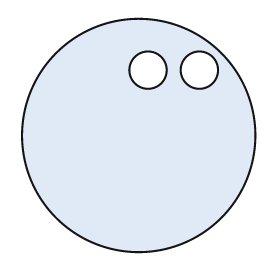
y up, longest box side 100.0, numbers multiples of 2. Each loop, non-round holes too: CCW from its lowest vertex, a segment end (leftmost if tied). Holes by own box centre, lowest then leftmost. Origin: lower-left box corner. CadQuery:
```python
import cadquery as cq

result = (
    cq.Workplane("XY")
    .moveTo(50.0, 50.0)
    .circle(50.0)
    .moveTo(54.0, 78.0)
    .circle(8.0)
    .moveTo(76.0, 78.0)
    .circle(8.0)
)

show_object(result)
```